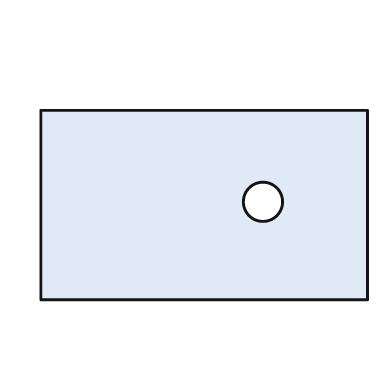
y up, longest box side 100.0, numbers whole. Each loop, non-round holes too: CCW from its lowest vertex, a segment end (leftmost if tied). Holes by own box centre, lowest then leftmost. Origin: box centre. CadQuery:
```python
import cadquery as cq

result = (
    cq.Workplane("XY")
    .moveTo(-50.0, -29.0)
    .lineTo(50.0, -29.0)
    .lineTo(50.0, 29.0)
    .lineTo(-50.0, 29.0)
    .close()
    .moveTo(18.0, 1.0)
    .circle(6.0)
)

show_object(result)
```